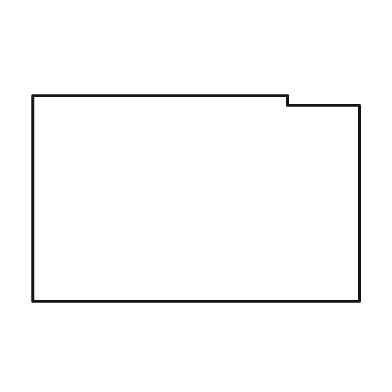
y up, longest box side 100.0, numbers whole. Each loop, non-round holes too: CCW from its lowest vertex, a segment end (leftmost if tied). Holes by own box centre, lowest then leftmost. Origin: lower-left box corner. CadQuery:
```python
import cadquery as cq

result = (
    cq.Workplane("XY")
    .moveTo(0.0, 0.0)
    .lineTo(100.0, 0.0)
    .lineTo(100.0, 60.0)
    .lineTo(78.0, 60.0)
    .lineTo(78.0, 63.0)
    .lineTo(0.0, 63.0)
    .close()
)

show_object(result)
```